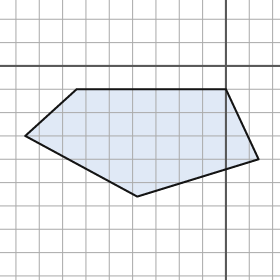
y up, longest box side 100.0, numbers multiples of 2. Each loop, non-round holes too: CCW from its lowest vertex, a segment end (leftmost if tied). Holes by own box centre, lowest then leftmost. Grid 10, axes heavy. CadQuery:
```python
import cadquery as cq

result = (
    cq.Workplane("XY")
    .moveTo(-38.0, -56.0)
    .lineTo(14.0, -40.0)
    .lineTo(0.0, -10.0)
    .lineTo(-64.0, -10.0)
    .lineTo(-86.0, -30.0)
    .close()
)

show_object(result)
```